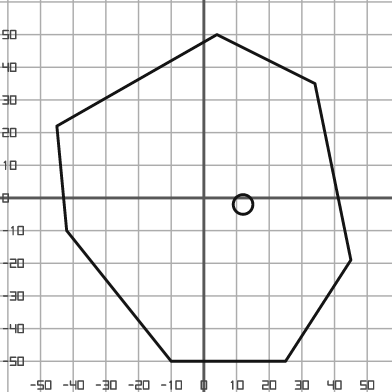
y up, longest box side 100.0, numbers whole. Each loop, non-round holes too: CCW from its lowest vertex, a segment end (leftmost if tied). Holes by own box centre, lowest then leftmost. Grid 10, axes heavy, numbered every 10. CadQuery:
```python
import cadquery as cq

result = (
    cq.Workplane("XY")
    .moveTo(-10.0, -50.0)
    .lineTo(25.0, -50.0)
    .lineTo(45.0, -19.0)
    .lineTo(34.0, 35.0)
    .lineTo(4.0, 50.0)
    .lineTo(-45.0, 22.0)
    .lineTo(-42.0, -10.0)
    .close()
    .moveTo(12.0, -2.0)
    .circle(3.0)
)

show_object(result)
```